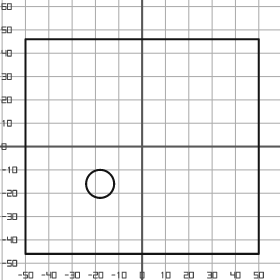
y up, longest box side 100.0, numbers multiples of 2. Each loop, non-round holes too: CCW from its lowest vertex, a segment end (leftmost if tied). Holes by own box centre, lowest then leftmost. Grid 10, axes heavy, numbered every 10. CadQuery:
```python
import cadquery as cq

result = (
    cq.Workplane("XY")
    .moveTo(-50.0, -46.0)
    .lineTo(50.0, -46.0)
    .lineTo(50.0, 46.0)
    .lineTo(-50.0, 46.0)
    .close()
    .moveTo(-18.0, -16.0)
    .circle(6.0)
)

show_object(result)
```